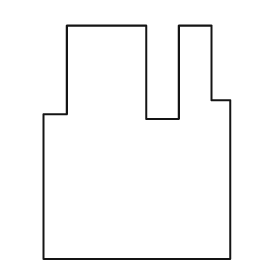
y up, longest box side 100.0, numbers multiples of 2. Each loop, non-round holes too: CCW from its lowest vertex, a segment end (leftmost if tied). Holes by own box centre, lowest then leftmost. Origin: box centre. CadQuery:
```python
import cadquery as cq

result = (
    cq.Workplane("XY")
    .moveTo(-40.0, -50.0)
    .lineTo(40.0, -50.0)
    .lineTo(40.0, 18.0)
    .lineTo(32.0, 18.0)
    .lineTo(32.0, 50.0)
    .lineTo(18.0, 50.0)
    .lineTo(18.0, 10.0)
    .lineTo(4.0, 10.0)
    .lineTo(4.0, 50.0)
    .lineTo(-30.0, 50.0)
    .lineTo(-30.0, 12.0)
    .lineTo(-40.0, 12.0)
    .close()
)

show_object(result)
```